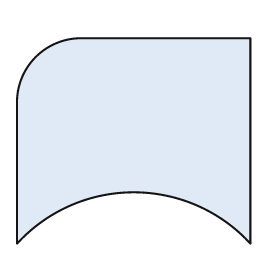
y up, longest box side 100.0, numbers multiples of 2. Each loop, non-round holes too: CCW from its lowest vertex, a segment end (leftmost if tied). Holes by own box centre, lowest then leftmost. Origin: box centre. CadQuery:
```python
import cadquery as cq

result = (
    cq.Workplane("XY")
    .moveTo(-50.0, -44.0)
    .threePointArc((0.0, -22.0), (50.0, -44.0))
    .lineTo(50.0, 44.0)
    .lineTo(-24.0, 44.0)
    .threePointArc((-42.0, 36.0), (-50.0, 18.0))
    .close()
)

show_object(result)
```